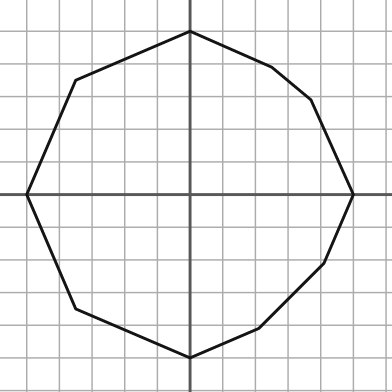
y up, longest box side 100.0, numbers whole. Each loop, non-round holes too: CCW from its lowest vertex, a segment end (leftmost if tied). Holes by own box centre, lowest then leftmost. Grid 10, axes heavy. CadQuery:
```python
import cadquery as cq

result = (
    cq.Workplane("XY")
    .moveTo(0.0, -50.0)
    .lineTo(21.0, -41.0)
    .lineTo(41.0, -21.0)
    .lineTo(50.0, 0.0)
    .lineTo(37.0, 29.0)
    .lineTo(25.0, 39.0)
    .lineTo(0.0, 50.0)
    .lineTo(-35.0, 35.0)
    .lineTo(-50.0, 0.0)
    .lineTo(-35.0, -35.0)
    .close()
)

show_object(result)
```